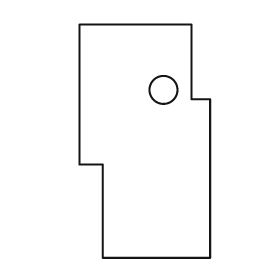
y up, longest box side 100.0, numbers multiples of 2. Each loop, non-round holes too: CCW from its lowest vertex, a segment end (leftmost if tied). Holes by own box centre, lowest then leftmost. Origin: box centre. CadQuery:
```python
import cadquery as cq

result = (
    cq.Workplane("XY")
    .moveTo(-18.0, -50.0)
    .lineTo(28.0, -50.0)
    .lineTo(28.0, 18.0)
    .lineTo(20.0, 18.0)
    .lineTo(20.0, 50.0)
    .lineTo(-28.0, 50.0)
    .lineTo(-28.0, -10.0)
    .lineTo(-18.0, -10.0)
    .close()
    .moveTo(8.0, 22.0)
    .circle(6.0)
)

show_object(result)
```